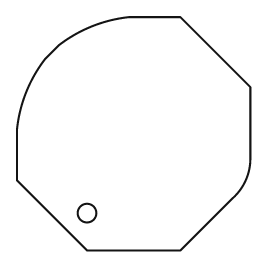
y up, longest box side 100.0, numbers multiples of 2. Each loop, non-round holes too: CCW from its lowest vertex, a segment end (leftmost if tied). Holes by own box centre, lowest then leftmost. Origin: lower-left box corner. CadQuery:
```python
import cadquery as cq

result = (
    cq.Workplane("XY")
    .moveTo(30.0, 0.0)
    .lineTo(70.0, 0.0)
    .lineTo(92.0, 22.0)
    .threePointArc((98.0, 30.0), (100.0, 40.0))
    .lineTo(100.0, 70.0)
    .lineTo(70.0, 100.0)
    .lineTo(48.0, 100.0)
    .threePointArc((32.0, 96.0), (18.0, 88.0))
    .lineTo(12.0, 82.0)
    .threePointArc((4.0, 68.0), (0.0, 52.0))
    .lineTo(0.0, 30.0)
    .close()
    .moveTo(30.0, 16.0)
    .circle(4.0)
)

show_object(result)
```